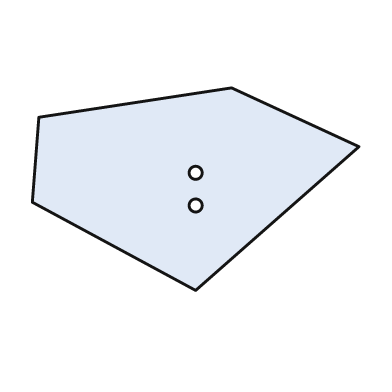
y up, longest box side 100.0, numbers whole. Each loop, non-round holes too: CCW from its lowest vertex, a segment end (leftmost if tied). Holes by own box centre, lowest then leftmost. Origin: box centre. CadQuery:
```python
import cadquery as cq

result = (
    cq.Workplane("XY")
    .moveTo(0.0, -31.0)
    .lineTo(50.0, 13.0)
    .lineTo(11.0, 31.0)
    .lineTo(-48.0, 22.0)
    .lineTo(-50.0, -4.0)
    .close()
    .moveTo(0.0, -5.0)
    .circle(2.0)
    .moveTo(0.0, 5.0)
    .circle(2.0)
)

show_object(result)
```